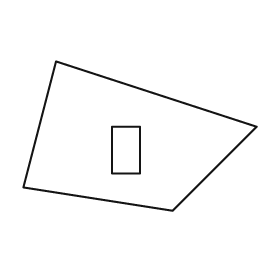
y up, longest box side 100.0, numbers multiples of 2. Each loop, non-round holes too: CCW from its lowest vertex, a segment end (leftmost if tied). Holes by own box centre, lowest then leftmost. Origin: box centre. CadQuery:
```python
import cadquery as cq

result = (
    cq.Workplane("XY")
    .moveTo(14.0, -32.0)
    .lineTo(50.0, 4.0)
    .lineTo(-36.0, 32.0)
    .lineTo(-50.0, -22.0)
    .close()
    .moveTo(-12.0, -16.0)
    .lineTo(0.0, -16.0)
    .lineTo(0.0, 4.0)
    .lineTo(-12.0, 4.0)
    .close()
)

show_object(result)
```